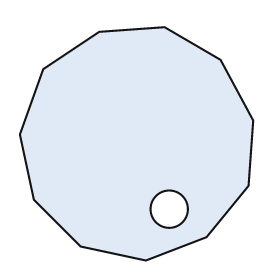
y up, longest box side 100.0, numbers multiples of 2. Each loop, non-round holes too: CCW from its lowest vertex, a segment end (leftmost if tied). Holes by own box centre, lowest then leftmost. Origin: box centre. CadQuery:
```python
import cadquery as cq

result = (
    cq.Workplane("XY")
    .moveTo(4.0, -50.0)
    .lineTo(30.0, -40.0)
    .lineTo(48.0, -18.0)
    .lineTo(50.0, 10.0)
    .lineTo(36.0, 36.0)
    .lineTo(12.0, 50.0)
    .lineTo(-16.0, 48.0)
    .lineTo(-40.0, 32.0)
    .lineTo(-50.0, 4.0)
    .lineTo(-44.0, -24.0)
    .lineTo(-24.0, -44.0)
    .close()
    .moveTo(14.0, -28.0)
    .circle(8.0)
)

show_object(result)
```